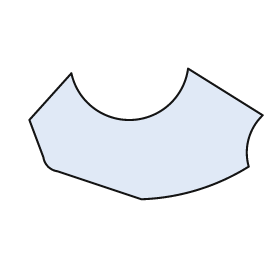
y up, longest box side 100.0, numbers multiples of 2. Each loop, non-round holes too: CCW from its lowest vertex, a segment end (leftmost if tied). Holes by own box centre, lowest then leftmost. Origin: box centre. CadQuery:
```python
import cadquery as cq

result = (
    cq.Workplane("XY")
    .moveTo(-2.0, -28.0)
    .threePointArc((22.0, -24.0), (44.0, -14.0))
    .threePointArc((44.0, -2.0), (50.0, 8.0))
    .lineTo(18.0, 28.0)
    .threePointArc((-6.0, 6.0), (-32.0, 26.0))
    .lineTo(-50.0, 6.0)
    .lineTo(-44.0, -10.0)
    .threePointArc((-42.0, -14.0), (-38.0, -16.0))
    .close()
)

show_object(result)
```